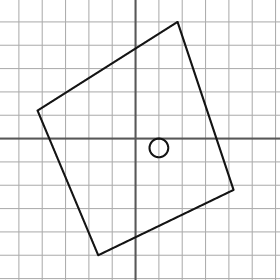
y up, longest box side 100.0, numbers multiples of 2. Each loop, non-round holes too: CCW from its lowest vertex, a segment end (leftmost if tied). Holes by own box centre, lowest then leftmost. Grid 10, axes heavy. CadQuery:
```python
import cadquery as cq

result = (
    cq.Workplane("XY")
    .moveTo(-16.0, -50.0)
    .lineTo(42.0, -22.0)
    .lineTo(18.0, 50.0)
    .lineTo(-42.0, 12.0)
    .close()
    .moveTo(10.0, -4.0)
    .circle(4.0)
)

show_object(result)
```